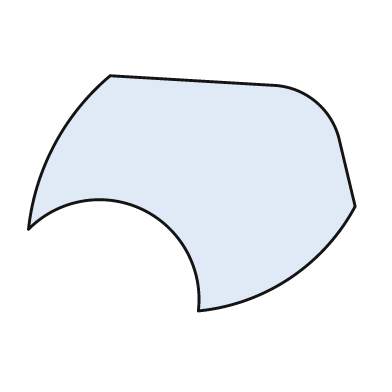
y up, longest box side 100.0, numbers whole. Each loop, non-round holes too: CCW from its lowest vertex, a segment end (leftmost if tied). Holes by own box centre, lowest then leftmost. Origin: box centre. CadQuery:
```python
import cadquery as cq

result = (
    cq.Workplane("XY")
    .moveTo(2.0, -36.0)
    .threePointArc((30.0, -26.0), (50.0, -4.0))
    .lineTo(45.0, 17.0)
    .threePointArc((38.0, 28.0), (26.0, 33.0))
    .lineTo(-25.0, 36.0)
    .threePointArc((-42.0, 15.0), (-50.0, -11.0))
    .threePointArc((-15.0, -5.0), (2.0, -36.0))
    .close()
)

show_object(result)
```